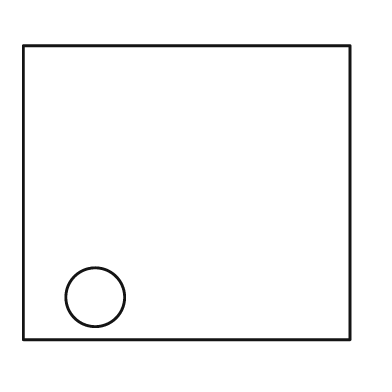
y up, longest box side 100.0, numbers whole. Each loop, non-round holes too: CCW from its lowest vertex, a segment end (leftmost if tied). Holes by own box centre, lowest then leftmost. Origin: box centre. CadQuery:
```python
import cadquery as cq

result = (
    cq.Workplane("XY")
    .moveTo(-50.0, -45.0)
    .lineTo(50.0, -45.0)
    .lineTo(50.0, 45.0)
    .lineTo(-50.0, 45.0)
    .close()
    .moveTo(-28.0, -32.0)
    .circle(9.0)
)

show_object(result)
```